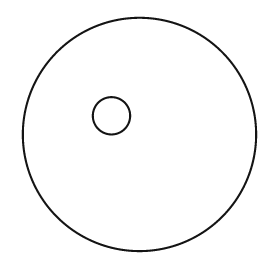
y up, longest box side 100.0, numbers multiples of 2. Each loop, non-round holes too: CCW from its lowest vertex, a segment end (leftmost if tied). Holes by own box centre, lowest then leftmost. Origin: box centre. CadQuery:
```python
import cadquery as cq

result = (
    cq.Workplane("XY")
    .moveTo(0.0, 0.0)
    .circle(50.0)
    .moveTo(-12.0, 8.0)
    .circle(8.0)
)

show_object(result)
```